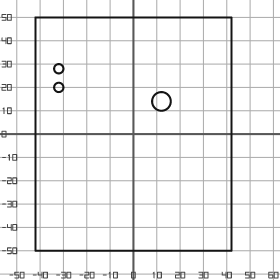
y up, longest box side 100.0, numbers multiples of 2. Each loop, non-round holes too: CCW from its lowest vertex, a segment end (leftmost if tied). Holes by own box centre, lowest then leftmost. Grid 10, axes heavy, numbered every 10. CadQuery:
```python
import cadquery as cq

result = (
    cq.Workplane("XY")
    .moveTo(-42.0, -50.0)
    .lineTo(42.0, -50.0)
    .lineTo(42.0, 50.0)
    .lineTo(-42.0, 50.0)
    .close()
    .moveTo(12.0, 14.0)
    .circle(4.0)
    .moveTo(-32.0, 20.0)
    .circle(2.0)
    .moveTo(-32.0, 28.0)
    .circle(2.0)
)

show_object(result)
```